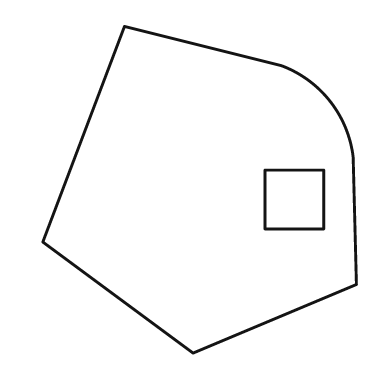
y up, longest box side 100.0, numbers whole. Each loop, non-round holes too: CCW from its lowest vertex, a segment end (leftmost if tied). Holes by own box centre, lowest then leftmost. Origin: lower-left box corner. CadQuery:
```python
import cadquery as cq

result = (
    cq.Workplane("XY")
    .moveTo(46.0, 0.0)
    .lineTo(96.0, 21.0)
    .lineTo(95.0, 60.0)
    .threePointArc((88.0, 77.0), (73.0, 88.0))
    .lineTo(25.0, 100.0)
    .lineTo(0.0, 34.0)
    .close()
    .moveTo(68.0, 38.0)
    .lineTo(86.0, 38.0)
    .lineTo(86.0, 56.0)
    .lineTo(68.0, 56.0)
    .close()
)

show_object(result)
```